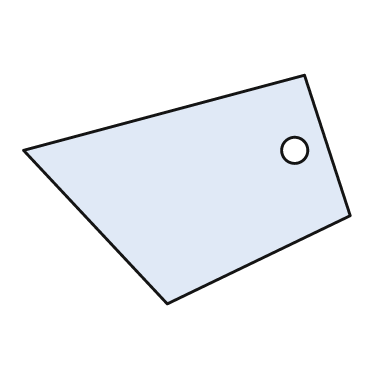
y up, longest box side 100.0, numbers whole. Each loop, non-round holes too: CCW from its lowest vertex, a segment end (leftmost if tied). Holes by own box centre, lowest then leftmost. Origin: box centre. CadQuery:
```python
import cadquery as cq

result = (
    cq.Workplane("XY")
    .moveTo(-6.0, -35.0)
    .lineTo(50.0, -8.0)
    .lineTo(36.0, 35.0)
    .lineTo(-50.0, 12.0)
    .close()
    .moveTo(33.0, 12.0)
    .circle(4.0)
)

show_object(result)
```